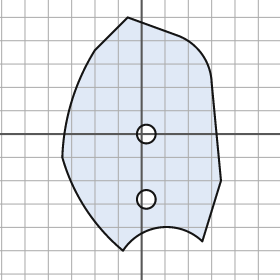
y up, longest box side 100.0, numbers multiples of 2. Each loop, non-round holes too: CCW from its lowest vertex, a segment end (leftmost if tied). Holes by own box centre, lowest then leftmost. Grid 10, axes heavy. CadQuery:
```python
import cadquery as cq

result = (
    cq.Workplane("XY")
    .moveTo(-8.0, -50.0)
    .threePointArc((8.0, -40.0), (26.0, -46.0))
    .lineTo(34.0, -20.0)
    .lineTo(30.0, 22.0)
    .threePointArc((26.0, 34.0), (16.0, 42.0))
    .lineTo(-6.0, 50.0)
    .lineTo(-20.0, 36.0)
    .threePointArc((-30.0, 14.0), (-34.0, -10.0))
    .threePointArc((-24.0, -32.0), (-8.0, -50.0))
    .close()
    .moveTo(2.0, -28.0)
    .circle(4.0)
    .moveTo(2.0, 0.0)
    .circle(4.0)
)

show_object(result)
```